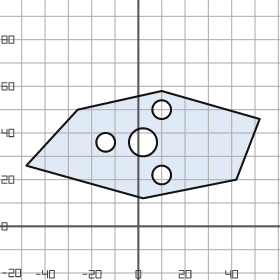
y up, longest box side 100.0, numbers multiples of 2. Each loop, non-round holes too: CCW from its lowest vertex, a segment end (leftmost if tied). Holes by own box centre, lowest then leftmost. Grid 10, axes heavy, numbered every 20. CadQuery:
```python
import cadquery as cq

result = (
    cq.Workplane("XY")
    .moveTo(2.0, 12.0)
    .lineTo(42.0, 20.0)
    .lineTo(52.0, 46.0)
    .lineTo(10.0, 58.0)
    .lineTo(-26.0, 50.0)
    .lineTo(-48.0, 26.0)
    .close()
    .moveTo(10.0, 22.0)
    .circle(4.0)
    .moveTo(-14.0, 36.0)
    .circle(4.0)
    .moveTo(2.0, 36.0)
    .circle(6.0)
    .moveTo(10.0, 50.0)
    .circle(4.0)
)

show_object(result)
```